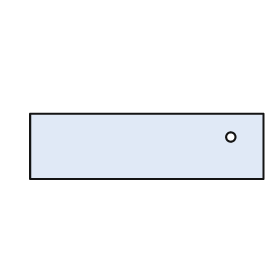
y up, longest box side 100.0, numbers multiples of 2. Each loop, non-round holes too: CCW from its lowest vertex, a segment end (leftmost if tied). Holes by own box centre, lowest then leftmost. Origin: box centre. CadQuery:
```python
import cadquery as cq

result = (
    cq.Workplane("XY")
    .moveTo(-50.0, -14.0)
    .lineTo(50.0, -14.0)
    .lineTo(50.0, 14.0)
    .lineTo(-50.0, 14.0)
    .close()
    .moveTo(36.0, 4.0)
    .circle(2.0)
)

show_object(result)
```